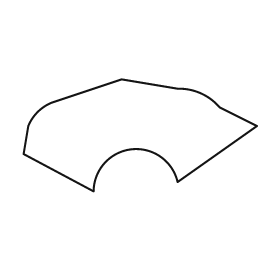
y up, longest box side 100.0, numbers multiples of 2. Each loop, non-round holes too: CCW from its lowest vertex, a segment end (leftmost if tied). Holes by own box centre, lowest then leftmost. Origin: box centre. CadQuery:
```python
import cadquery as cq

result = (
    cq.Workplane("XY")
    .moveTo(-20.0, -24.0)
    .threePointArc((-4.0, -6.0), (16.0, -20.0))
    .lineTo(50.0, 4.0)
    .lineTo(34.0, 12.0)
    .threePointArc((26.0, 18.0), (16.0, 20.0))
    .lineTo(-8.0, 24.0)
    .lineTo(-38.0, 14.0)
    .threePointArc((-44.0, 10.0), (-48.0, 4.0))
    .lineTo(-50.0, -8.0)
    .close()
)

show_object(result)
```